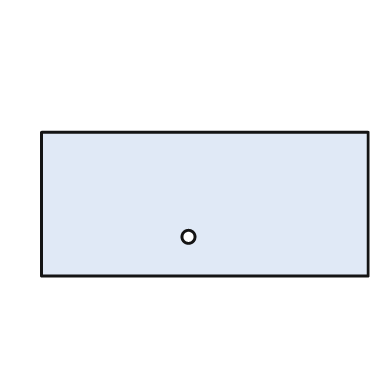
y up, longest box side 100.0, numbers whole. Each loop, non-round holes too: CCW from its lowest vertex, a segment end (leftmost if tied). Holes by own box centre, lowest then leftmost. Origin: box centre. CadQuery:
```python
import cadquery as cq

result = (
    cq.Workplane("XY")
    .moveTo(-50.0, -22.0)
    .lineTo(50.0, -22.0)
    .lineTo(50.0, 22.0)
    .lineTo(-50.0, 22.0)
    .close()
    .moveTo(-5.0, -10.0)
    .circle(2.0)
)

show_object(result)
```